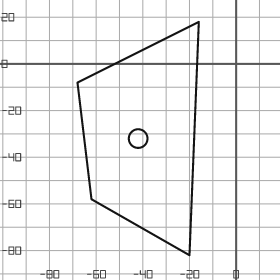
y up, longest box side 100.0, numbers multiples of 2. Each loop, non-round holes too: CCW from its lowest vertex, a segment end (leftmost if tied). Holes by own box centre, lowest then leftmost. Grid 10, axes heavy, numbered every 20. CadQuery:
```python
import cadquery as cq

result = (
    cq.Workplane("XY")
    .moveTo(-20.0, -82.0)
    .lineTo(-16.0, 18.0)
    .lineTo(-68.0, -8.0)
    .lineTo(-62.0, -58.0)
    .close()
    .moveTo(-42.0, -32.0)
    .circle(4.0)
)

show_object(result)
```